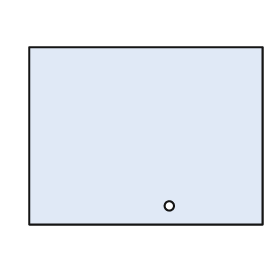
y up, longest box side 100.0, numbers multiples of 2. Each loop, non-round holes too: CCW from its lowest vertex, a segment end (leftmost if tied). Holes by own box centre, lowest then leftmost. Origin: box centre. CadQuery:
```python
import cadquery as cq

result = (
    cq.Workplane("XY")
    .moveTo(-50.0, -38.0)
    .lineTo(50.0, -38.0)
    .lineTo(50.0, 38.0)
    .lineTo(-50.0, 38.0)
    .close()
    .moveTo(10.0, -30.0)
    .circle(2.0)
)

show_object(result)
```